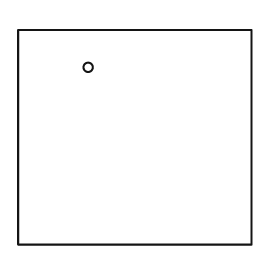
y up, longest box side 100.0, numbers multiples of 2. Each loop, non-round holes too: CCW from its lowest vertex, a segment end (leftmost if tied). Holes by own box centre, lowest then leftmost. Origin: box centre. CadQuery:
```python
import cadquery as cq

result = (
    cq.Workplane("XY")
    .moveTo(-50.0, -46.0)
    .lineTo(50.0, -46.0)
    .lineTo(50.0, 46.0)
    .lineTo(-50.0, 46.0)
    .close()
    .moveTo(-20.0, 30.0)
    .circle(2.0)
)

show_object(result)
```